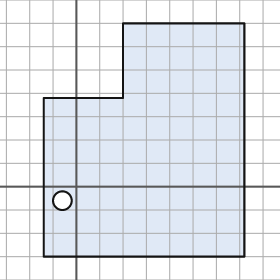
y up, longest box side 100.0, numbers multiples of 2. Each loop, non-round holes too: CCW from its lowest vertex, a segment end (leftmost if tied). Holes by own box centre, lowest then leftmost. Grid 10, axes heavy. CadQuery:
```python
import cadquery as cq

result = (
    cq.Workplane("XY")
    .moveTo(-14.0, -30.0)
    .lineTo(72.0, -30.0)
    .lineTo(72.0, 70.0)
    .lineTo(20.0, 70.0)
    .lineTo(20.0, 38.0)
    .lineTo(-14.0, 38.0)
    .close()
    .moveTo(-6.0, -6.0)
    .circle(4.0)
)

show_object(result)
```